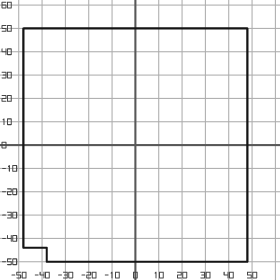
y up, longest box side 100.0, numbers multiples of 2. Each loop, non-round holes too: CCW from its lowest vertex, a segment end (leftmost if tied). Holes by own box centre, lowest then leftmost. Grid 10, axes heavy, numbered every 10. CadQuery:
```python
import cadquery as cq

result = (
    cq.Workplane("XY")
    .moveTo(-38.0, -50.0)
    .lineTo(48.0, -50.0)
    .lineTo(48.0, 50.0)
    .lineTo(-48.0, 50.0)
    .lineTo(-48.0, -44.0)
    .lineTo(-38.0, -44.0)
    .close()
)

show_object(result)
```